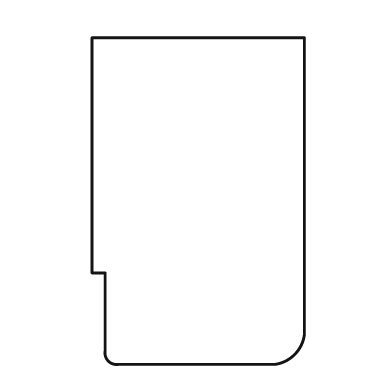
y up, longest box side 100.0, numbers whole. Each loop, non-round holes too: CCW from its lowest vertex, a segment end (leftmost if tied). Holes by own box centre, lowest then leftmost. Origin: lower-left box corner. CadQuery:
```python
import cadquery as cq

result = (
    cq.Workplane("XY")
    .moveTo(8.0, 0.0)
    .lineTo(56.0, 0.0)
    .threePointArc((62.0, 3.0), (65.0, 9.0))
    .lineTo(65.0, 100.0)
    .lineTo(0.0, 100.0)
    .lineTo(0.0, 28.0)
    .lineTo(4.0, 28.0)
    .lineTo(4.0, 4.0)
    .threePointArc((5.0, 1.0), (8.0, 0.0))
    .close()
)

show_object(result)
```